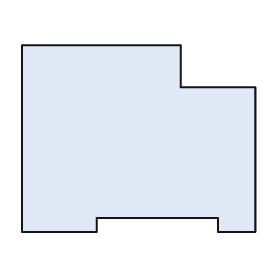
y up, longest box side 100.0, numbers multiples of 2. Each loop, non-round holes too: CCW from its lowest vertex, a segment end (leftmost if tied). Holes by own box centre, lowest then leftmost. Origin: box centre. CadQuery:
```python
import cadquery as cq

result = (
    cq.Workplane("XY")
    .moveTo(-50.0, -40.0)
    .lineTo(-18.0, -40.0)
    .lineTo(-18.0, -34.0)
    .lineTo(34.0, -34.0)
    .lineTo(34.0, -40.0)
    .lineTo(50.0, -40.0)
    .lineTo(50.0, 22.0)
    .lineTo(18.0, 22.0)
    .lineTo(18.0, 40.0)
    .lineTo(-50.0, 40.0)
    .close()
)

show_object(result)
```